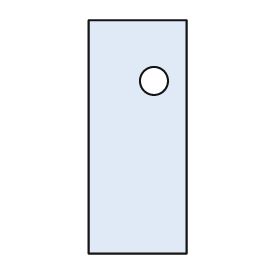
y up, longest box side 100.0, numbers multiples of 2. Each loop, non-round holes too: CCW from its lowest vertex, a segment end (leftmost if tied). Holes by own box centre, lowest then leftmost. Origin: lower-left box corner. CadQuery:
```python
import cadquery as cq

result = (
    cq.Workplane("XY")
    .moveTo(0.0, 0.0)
    .lineTo(42.0, 0.0)
    .lineTo(42.0, 100.0)
    .lineTo(0.0, 100.0)
    .close()
    .moveTo(28.0, 74.0)
    .circle(6.0)
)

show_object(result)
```